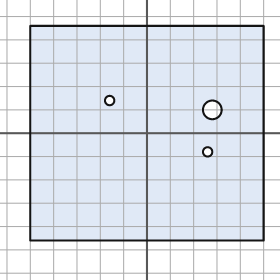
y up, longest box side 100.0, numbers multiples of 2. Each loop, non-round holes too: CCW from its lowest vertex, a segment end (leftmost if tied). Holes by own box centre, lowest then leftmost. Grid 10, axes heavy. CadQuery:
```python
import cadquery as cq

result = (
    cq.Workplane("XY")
    .moveTo(-50.0, -46.0)
    .lineTo(50.0, -46.0)
    .lineTo(50.0, 46.0)
    .lineTo(-50.0, 46.0)
    .close()
    .moveTo(26.0, -8.0)
    .circle(2.0)
    .moveTo(28.0, 10.0)
    .circle(4.0)
    .moveTo(-16.0, 14.0)
    .circle(2.0)
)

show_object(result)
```